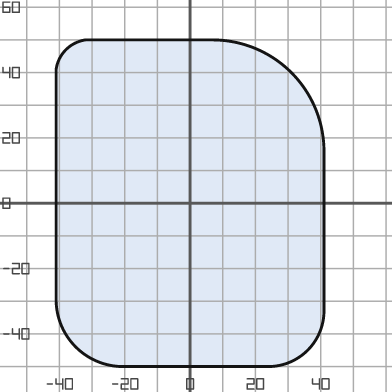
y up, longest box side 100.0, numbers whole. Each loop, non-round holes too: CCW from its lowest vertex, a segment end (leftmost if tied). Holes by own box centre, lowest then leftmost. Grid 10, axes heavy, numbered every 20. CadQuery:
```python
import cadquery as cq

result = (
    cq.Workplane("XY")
    .moveTo(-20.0, -50.0)
    .lineTo(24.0, -50.0)
    .threePointArc((36.0, -45.0), (41.0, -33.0))
    .lineTo(41.0, 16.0)
    .threePointArc((31.0, 40.0), (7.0, 50.0))
    .lineTo(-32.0, 50.0)
    .threePointArc((-38.0, 47.0), (-41.0, 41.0))
    .lineTo(-41.0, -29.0)
    .threePointArc((-35.0, -44.0), (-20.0, -50.0))
    .close()
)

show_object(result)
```